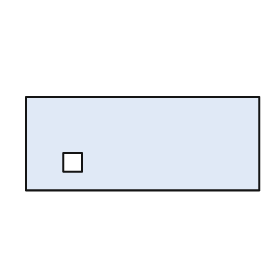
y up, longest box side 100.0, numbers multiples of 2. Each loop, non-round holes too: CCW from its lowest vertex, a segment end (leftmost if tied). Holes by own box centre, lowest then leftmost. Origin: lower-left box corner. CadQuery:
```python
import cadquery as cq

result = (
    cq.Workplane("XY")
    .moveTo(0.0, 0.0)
    .lineTo(100.0, 0.0)
    .lineTo(100.0, 40.0)
    .lineTo(0.0, 40.0)
    .close()
    .moveTo(16.0, 8.0)
    .lineTo(24.0, 8.0)
    .lineTo(24.0, 16.0)
    .lineTo(16.0, 16.0)
    .close()
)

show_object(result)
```